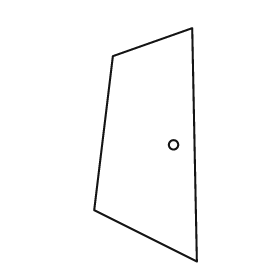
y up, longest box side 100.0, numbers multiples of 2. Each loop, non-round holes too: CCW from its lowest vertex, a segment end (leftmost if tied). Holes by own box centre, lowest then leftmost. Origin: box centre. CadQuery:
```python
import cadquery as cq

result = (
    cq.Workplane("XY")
    .moveTo(22.0, -50.0)
    .lineTo(20.0, 50.0)
    .lineTo(-14.0, 38.0)
    .lineTo(-22.0, -28.0)
    .close()
    .moveTo(12.0, 0.0)
    .circle(2.0)
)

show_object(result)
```